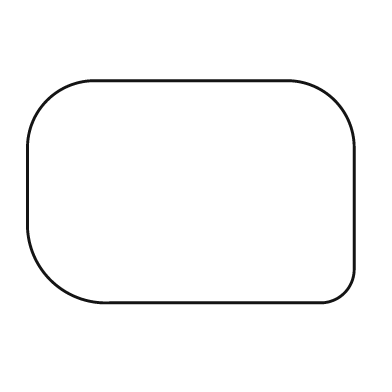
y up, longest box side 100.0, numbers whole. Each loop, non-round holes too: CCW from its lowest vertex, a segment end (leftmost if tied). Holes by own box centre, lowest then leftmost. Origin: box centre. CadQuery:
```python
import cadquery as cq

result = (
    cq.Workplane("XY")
    .moveTo(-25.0, -34.0)
    .lineTo(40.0, -34.0)
    .threePointArc((47.0, -31.0), (50.0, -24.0))
    .lineTo(50.0, 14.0)
    .threePointArc((44.0, 28.0), (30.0, 34.0))
    .lineTo(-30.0, 34.0)
    .threePointArc((-44.0, 28.0), (-50.0, 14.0))
    .lineTo(-50.0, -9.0)
    .threePointArc((-43.0, -27.0), (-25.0, -34.0))
    .close()
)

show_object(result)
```